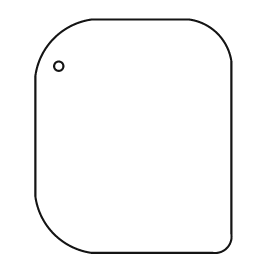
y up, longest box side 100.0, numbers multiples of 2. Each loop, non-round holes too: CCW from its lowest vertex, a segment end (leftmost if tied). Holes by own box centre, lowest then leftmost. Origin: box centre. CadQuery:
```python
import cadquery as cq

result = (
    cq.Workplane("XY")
    .moveTo(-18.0, -50.0)
    .lineTo(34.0, -50.0)
    .threePointArc((40.0, -48.0), (42.0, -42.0))
    .lineTo(42.0, 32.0)
    .threePointArc((36.0, 44.0), (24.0, 50.0))
    .lineTo(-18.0, 50.0)
    .threePointArc((-34.0, 42.0), (-42.0, 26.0))
    .lineTo(-42.0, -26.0)
    .threePointArc((-34.0, -42.0), (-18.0, -50.0))
    .close()
    .moveTo(-32.0, 30.0)
    .circle(2.0)
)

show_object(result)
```